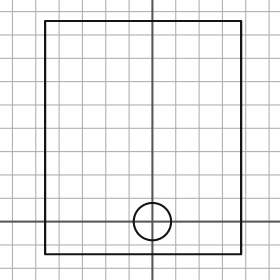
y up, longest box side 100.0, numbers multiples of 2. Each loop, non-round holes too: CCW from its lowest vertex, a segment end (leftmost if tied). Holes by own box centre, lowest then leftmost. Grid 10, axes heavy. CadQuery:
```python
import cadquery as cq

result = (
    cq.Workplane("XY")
    .moveTo(-46.0, -14.0)
    .lineTo(38.0, -14.0)
    .lineTo(38.0, 86.0)
    .lineTo(-46.0, 86.0)
    .close()
    .moveTo(0.0, 0.0)
    .circle(8.0)
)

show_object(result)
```